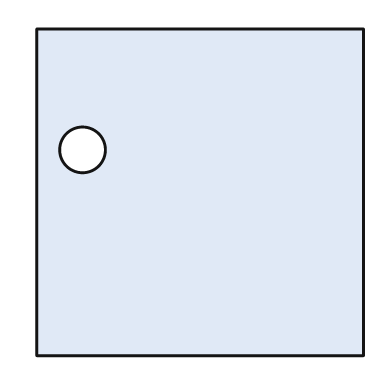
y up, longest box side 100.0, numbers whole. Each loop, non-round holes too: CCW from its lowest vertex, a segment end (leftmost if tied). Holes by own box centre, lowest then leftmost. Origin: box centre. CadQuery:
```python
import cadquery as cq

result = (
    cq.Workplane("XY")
    .moveTo(-50.0, -50.0)
    .lineTo(50.0, -50.0)
    .lineTo(50.0, 50.0)
    .lineTo(-50.0, 50.0)
    .close()
    .moveTo(-36.0, 13.0)
    .circle(7.0)
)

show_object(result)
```